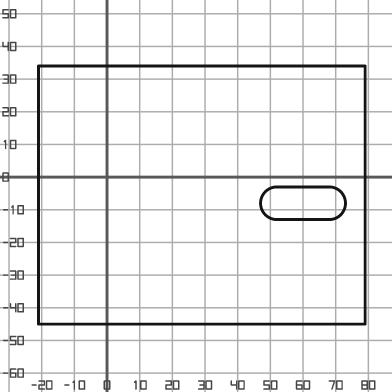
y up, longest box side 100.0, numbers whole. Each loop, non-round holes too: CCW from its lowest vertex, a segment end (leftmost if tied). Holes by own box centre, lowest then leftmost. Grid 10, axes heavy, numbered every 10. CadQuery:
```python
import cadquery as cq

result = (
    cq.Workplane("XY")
    .moveTo(-21.0, -45.0)
    .lineTo(79.0, -45.0)
    .lineTo(79.0, 34.0)
    .lineTo(-21.0, 34.0)
    .close()
    .moveTo(52.0, -13.0)
    .lineTo(68.0, -13.0)
    .threePointArc((73.0, -8.0), (68.0, -3.0))
    .lineTo(52.0, -3.0)
    .threePointArc((47.0, -8.0), (52.0, -13.0))
    .close()
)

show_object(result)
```